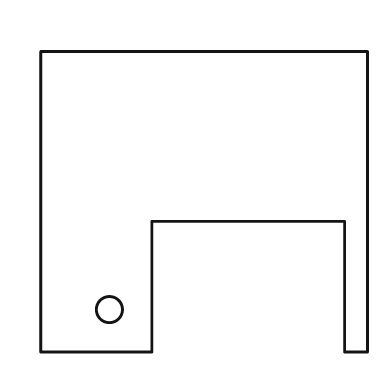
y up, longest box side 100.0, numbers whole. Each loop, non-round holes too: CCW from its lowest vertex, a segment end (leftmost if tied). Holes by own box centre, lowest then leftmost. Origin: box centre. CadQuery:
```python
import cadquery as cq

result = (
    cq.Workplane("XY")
    .moveTo(-50.0, -46.0)
    .lineTo(-16.0, -46.0)
    .lineTo(-16.0, -6.0)
    .lineTo(43.0, -6.0)
    .lineTo(43.0, -46.0)
    .lineTo(50.0, -46.0)
    .lineTo(50.0, 46.0)
    .lineTo(-50.0, 46.0)
    .close()
    .moveTo(-29.0, -33.0)
    .circle(4.0)
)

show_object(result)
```